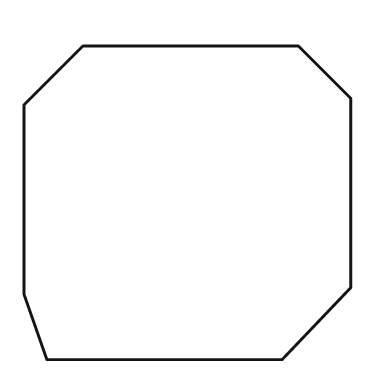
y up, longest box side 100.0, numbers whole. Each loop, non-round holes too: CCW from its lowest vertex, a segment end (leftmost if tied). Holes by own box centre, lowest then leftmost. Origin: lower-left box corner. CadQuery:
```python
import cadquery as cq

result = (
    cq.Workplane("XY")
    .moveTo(7.0, 0.0)
    .lineTo(79.0, 0.0)
    .lineTo(100.0, 22.0)
    .lineTo(100.0, 80.0)
    .lineTo(84.0, 96.0)
    .lineTo(18.0, 96.0)
    .lineTo(0.0, 78.0)
    .lineTo(0.0, 20.0)
    .close()
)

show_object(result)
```